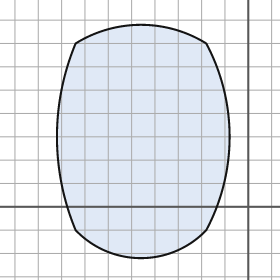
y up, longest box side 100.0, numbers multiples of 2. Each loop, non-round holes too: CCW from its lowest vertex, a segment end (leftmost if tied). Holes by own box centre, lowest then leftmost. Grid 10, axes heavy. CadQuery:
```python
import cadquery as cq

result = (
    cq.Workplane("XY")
    .moveTo(-74.0, -10.0)
    .threePointArc((-46.0, -22.0), (-18.0, -10.0))
    .threePointArc((-8.0, 30.0), (-18.0, 70.0))
    .threePointArc((-46.0, 78.0), (-74.0, 70.0))
    .threePointArc((-82.0, 30.0), (-74.0, -10.0))
    .close()
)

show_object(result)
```